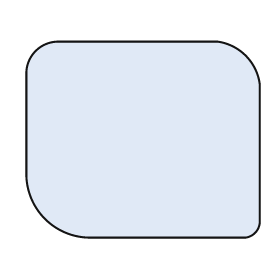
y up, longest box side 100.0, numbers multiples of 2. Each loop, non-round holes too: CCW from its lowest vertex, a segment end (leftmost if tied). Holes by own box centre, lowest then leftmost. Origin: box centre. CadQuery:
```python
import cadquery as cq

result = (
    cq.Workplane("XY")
    .moveTo(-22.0, -42.0)
    .lineTo(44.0, -42.0)
    .threePointArc((48.0, -40.0), (50.0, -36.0))
    .lineTo(50.0, 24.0)
    .threePointArc((44.0, 36.0), (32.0, 42.0))
    .lineTo(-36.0, 42.0)
    .threePointArc((-46.0, 38.0), (-50.0, 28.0))
    .lineTo(-50.0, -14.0)
    .threePointArc((-42.0, -34.0), (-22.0, -42.0))
    .close()
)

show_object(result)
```